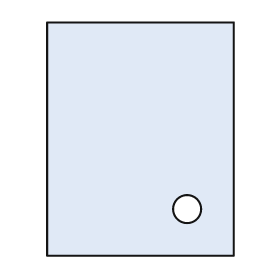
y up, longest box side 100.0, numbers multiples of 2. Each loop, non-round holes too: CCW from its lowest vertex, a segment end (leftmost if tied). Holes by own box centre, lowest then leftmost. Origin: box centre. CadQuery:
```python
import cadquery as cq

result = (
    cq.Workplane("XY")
    .moveTo(-40.0, -50.0)
    .lineTo(40.0, -50.0)
    .lineTo(40.0, 50.0)
    .lineTo(-40.0, 50.0)
    .close()
    .moveTo(20.0, -30.0)
    .circle(6.0)
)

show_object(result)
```